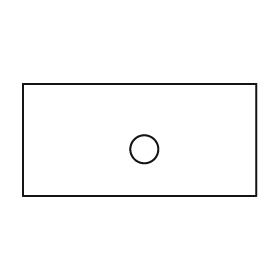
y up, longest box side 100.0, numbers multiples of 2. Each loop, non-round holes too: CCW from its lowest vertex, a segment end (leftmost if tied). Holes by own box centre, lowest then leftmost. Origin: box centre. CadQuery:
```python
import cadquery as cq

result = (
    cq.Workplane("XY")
    .moveTo(-50.0, -24.0)
    .lineTo(50.0, -24.0)
    .lineTo(50.0, 24.0)
    .lineTo(-50.0, 24.0)
    .close()
    .moveTo(2.0, -4.0)
    .circle(6.0)
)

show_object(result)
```